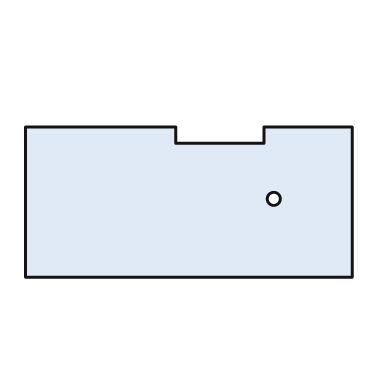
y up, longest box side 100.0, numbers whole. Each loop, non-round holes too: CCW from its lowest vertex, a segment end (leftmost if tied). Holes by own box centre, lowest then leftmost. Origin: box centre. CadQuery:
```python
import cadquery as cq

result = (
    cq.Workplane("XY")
    .moveTo(-50.0, -23.0)
    .lineTo(50.0, -23.0)
    .lineTo(50.0, 23.0)
    .lineTo(23.0, 23.0)
    .lineTo(23.0, 18.0)
    .lineTo(-4.0, 18.0)
    .lineTo(-4.0, 23.0)
    .lineTo(-50.0, 23.0)
    .close()
    .moveTo(26.0, 1.0)
    .circle(2.0)
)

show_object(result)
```